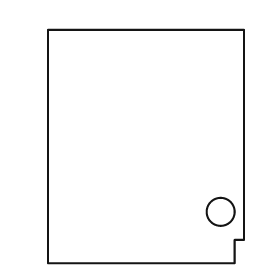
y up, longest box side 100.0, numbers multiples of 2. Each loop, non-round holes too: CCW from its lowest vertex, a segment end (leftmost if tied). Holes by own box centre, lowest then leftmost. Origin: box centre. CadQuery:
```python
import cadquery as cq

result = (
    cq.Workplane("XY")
    .moveTo(-42.0, -50.0)
    .lineTo(38.0, -50.0)
    .lineTo(38.0, -40.0)
    .lineTo(42.0, -40.0)
    .lineTo(42.0, 50.0)
    .lineTo(-42.0, 50.0)
    .close()
    .moveTo(32.0, -28.0)
    .circle(6.0)
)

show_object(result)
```